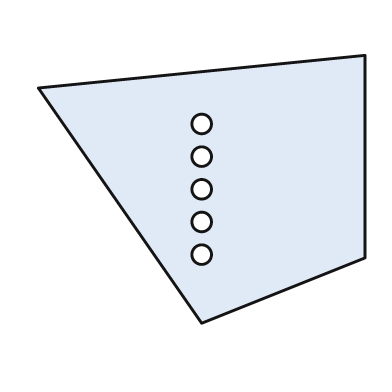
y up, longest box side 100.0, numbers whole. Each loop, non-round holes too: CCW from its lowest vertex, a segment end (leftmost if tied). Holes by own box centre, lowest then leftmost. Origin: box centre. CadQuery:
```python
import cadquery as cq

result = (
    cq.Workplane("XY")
    .moveTo(0.0, -41.0)
    .lineTo(50.0, -21.0)
    .lineTo(50.0, 41.0)
    .lineTo(-50.0, 31.0)
    .close()
    .moveTo(0.0, -20.0)
    .circle(3.0)
    .moveTo(0.0, -10.0)
    .circle(3.0)
    .moveTo(0.0, 0.0)
    .circle(3.0)
    .moveTo(0.0, 10.0)
    .circle(3.0)
    .moveTo(0.0, 20.0)
    .circle(3.0)
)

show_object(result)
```